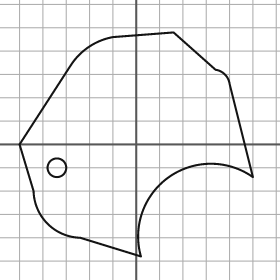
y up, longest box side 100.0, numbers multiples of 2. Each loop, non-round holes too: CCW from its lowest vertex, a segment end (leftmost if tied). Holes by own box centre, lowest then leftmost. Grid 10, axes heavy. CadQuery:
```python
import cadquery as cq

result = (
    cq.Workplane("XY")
    .moveTo(2.0, -48.0)
    .threePointArc((14.0, -14.0), (50.0, -14.0))
    .lineTo(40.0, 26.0)
    .threePointArc((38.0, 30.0), (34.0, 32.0))
    .lineTo(16.0, 48.0)
    .lineTo(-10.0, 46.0)
    .threePointArc((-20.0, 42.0), (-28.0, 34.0))
    .lineTo(-50.0, 0.0)
    .lineTo(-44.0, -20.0)
    .threePointArc((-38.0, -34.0), (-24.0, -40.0))
    .close()
    .moveTo(-34.0, -10.0)
    .circle(4.0)
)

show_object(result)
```